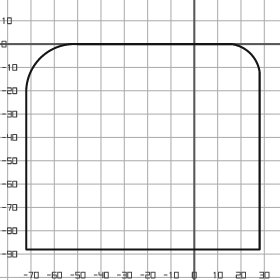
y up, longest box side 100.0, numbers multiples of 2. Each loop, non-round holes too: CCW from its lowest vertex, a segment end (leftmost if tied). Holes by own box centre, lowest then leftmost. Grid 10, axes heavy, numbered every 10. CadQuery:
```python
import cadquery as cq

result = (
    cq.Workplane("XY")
    .moveTo(-72.0, -88.0)
    .lineTo(28.0, -88.0)
    .lineTo(28.0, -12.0)
    .threePointArc((24.0, -4.0), (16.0, 0.0))
    .lineTo(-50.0, 0.0)
    .threePointArc((-66.0, -6.0), (-72.0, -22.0))
    .close()
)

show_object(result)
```